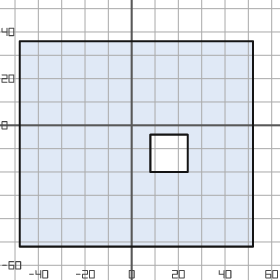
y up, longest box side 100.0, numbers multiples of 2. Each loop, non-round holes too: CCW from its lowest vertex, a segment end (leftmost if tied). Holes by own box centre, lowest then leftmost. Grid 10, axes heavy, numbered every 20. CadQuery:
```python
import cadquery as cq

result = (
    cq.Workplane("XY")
    .moveTo(-48.0, -52.0)
    .lineTo(52.0, -52.0)
    .lineTo(52.0, 36.0)
    .lineTo(-48.0, 36.0)
    .close()
    .moveTo(8.0, -20.0)
    .lineTo(24.0, -20.0)
    .lineTo(24.0, -4.0)
    .lineTo(8.0, -4.0)
    .close()
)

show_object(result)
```